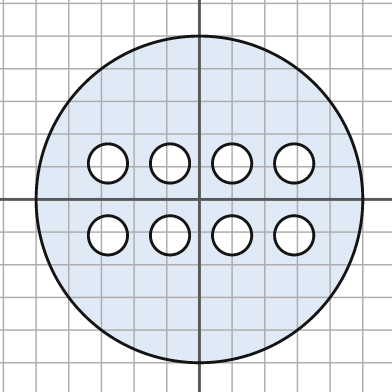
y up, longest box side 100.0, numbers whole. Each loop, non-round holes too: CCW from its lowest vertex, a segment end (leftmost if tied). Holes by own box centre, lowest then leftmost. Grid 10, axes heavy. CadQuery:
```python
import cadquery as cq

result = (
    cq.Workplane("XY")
    .moveTo(0.0, 0.0)
    .circle(50.0)
    .moveTo(-28.0, -11.0)
    .circle(6.0)
    .moveTo(-9.0, -11.0)
    .circle(6.0)
    .moveTo(10.0, -11.0)
    .circle(6.0)
    .moveTo(29.0, -11.0)
    .circle(6.0)
    .moveTo(-28.0, 11.0)
    .circle(6.0)
    .moveTo(-9.0, 11.0)
    .circle(6.0)
    .moveTo(10.0, 11.0)
    .circle(6.0)
    .moveTo(29.0, 11.0)
    .circle(6.0)
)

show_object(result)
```